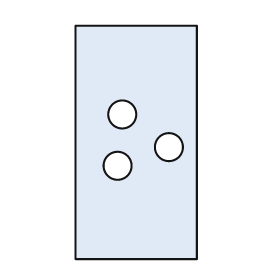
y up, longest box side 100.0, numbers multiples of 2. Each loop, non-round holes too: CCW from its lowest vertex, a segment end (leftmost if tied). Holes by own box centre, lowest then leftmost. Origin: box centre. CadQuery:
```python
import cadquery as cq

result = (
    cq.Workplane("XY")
    .moveTo(-26.0, -50.0)
    .lineTo(26.0, -50.0)
    .lineTo(26.0, 50.0)
    .lineTo(-26.0, 50.0)
    .close()
    .moveTo(-8.0, -10.0)
    .circle(6.0)
    .moveTo(14.0, -2.0)
    .circle(6.0)
    .moveTo(-6.0, 12.0)
    .circle(6.0)
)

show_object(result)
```